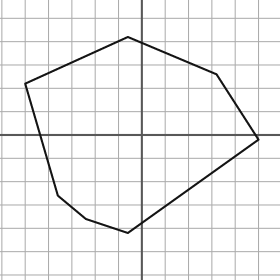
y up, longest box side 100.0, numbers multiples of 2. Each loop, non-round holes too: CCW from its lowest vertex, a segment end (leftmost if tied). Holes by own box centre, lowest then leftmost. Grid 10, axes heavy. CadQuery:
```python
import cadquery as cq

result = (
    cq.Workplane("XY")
    .moveTo(-6.0, -42.0)
    .lineTo(50.0, -2.0)
    .lineTo(32.0, 26.0)
    .lineTo(-6.0, 42.0)
    .lineTo(-50.0, 22.0)
    .lineTo(-36.0, -26.0)
    .lineTo(-24.0, -36.0)
    .close()
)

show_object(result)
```